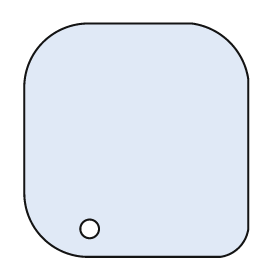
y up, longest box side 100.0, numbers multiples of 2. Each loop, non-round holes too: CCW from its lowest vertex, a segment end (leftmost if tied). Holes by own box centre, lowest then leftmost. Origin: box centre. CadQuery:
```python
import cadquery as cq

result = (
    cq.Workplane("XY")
    .moveTo(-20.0, -50.0)
    .lineTo(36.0, -50.0)
    .threePointArc((44.0, -46.0), (48.0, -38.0))
    .lineTo(48.0, 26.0)
    .threePointArc((40.0, 42.0), (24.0, 50.0))
    .lineTo(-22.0, 50.0)
    .threePointArc((-40.0, 42.0), (-48.0, 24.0))
    .lineTo(-48.0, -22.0)
    .threePointArc((-40.0, -42.0), (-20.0, -50.0))
    .close()
    .moveTo(-20.0, -38.0)
    .circle(4.0)
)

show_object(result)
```